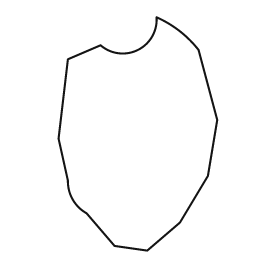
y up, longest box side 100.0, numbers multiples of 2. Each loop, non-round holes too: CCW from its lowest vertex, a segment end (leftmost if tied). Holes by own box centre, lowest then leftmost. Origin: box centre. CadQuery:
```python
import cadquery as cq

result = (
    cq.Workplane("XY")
    .moveTo(4.0, -50.0)
    .lineTo(18.0, -38.0)
    .lineTo(30.0, -18.0)
    .lineTo(34.0, 6.0)
    .lineTo(26.0, 36.0)
    .threePointArc((18.0, 44.0), (8.0, 50.0))
    .threePointArc((0.0, 36.0), (-16.0, 38.0))
    .lineTo(-30.0, 32.0)
    .lineTo(-34.0, -2.0)
    .lineTo(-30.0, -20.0)
    .threePointArc((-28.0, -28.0), (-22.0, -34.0))
    .lineTo(-10.0, -48.0)
    .close()
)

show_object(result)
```